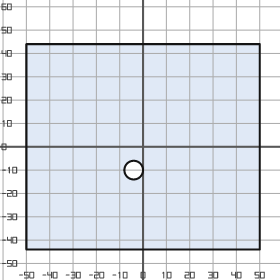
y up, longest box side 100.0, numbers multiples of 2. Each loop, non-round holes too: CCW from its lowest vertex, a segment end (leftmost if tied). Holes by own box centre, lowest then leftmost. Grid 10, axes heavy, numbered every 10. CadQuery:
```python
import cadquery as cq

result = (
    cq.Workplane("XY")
    .moveTo(-50.0, -44.0)
    .lineTo(50.0, -44.0)
    .lineTo(50.0, 44.0)
    .lineTo(-50.0, 44.0)
    .close()
    .moveTo(-4.0, -10.0)
    .circle(4.0)
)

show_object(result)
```